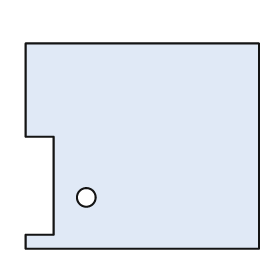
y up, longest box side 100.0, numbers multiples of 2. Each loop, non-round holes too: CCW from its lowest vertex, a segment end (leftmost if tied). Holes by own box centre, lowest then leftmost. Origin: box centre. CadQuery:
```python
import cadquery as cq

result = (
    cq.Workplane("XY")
    .moveTo(-50.0, -44.0)
    .lineTo(50.0, -44.0)
    .lineTo(50.0, 44.0)
    .lineTo(-50.0, 44.0)
    .lineTo(-50.0, 4.0)
    .lineTo(-38.0, 4.0)
    .lineTo(-38.0, -38.0)
    .lineTo(-50.0, -38.0)
    .close()
    .moveTo(-24.0, -22.0)
    .circle(4.0)
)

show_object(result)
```